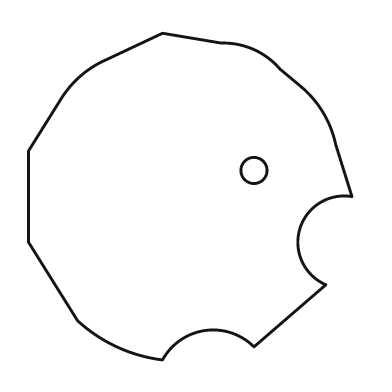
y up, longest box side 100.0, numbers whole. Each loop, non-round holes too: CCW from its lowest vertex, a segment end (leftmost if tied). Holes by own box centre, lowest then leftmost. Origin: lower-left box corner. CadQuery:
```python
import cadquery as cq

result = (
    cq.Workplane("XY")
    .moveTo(41.0, 0.0)
    .threePointArc((54.0, 9.0), (69.0, 4.0))
    .lineTo(91.0, 23.0)
    .threePointArc((83.0, 40.0), (99.0, 50.0))
    .lineTo(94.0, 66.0)
    .threePointArc((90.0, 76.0), (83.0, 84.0))
    .lineTo(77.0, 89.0)
    .threePointArc((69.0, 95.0), (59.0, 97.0))
    .lineTo(41.0, 100.0)
    .lineTo(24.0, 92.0)
    .threePointArc((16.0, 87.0), (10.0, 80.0))
    .lineTo(0.0, 64.0)
    .lineTo(0.0, 36.0)
    .lineTo(15.0, 12.0)
    .threePointArc((27.0, 4.0), (41.0, 0.0))
    .close()
    .moveTo(69.0, 58.0)
    .circle(4.0)
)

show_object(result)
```